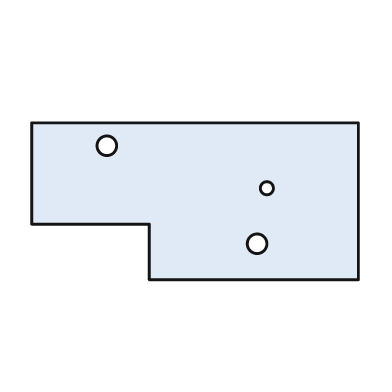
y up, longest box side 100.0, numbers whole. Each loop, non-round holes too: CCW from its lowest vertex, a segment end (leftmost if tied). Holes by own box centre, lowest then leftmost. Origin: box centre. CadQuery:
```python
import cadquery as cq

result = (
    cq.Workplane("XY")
    .moveTo(-14.0, -24.0)
    .lineTo(50.0, -24.0)
    .lineTo(50.0, 24.0)
    .lineTo(-50.0, 24.0)
    .lineTo(-50.0, -7.0)
    .lineTo(-14.0, -7.0)
    .close()
    .moveTo(19.0, -13.0)
    .circle(3.0)
    .moveTo(22.0, 4.0)
    .circle(2.0)
    .moveTo(-27.0, 17.0)
    .circle(3.0)
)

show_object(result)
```